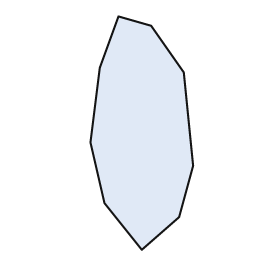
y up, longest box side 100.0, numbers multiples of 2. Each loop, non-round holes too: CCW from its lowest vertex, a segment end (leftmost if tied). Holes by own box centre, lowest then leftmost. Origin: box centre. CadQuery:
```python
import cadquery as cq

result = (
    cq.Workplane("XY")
    .moveTo(0.0, -50.0)
    .lineTo(16.0, -36.0)
    .lineTo(22.0, -14.0)
    .lineTo(18.0, 26.0)
    .lineTo(4.0, 46.0)
    .lineTo(-10.0, 50.0)
    .lineTo(-18.0, 28.0)
    .lineTo(-22.0, -4.0)
    .lineTo(-16.0, -30.0)
    .close()
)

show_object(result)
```